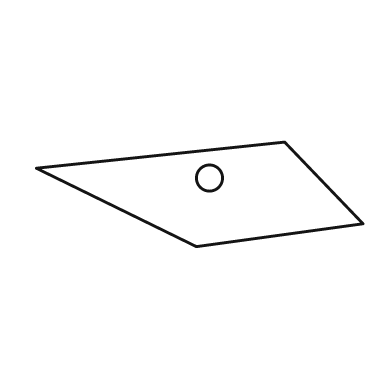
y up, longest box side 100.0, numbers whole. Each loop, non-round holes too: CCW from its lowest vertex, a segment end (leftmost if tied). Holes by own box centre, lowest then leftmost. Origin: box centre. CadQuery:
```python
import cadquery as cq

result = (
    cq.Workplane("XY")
    .moveTo(-1.0, -16.0)
    .lineTo(50.0, -9.0)
    .lineTo(26.0, 16.0)
    .lineTo(-50.0, 8.0)
    .close()
    .moveTo(3.0, 5.0)
    .circle(4.0)
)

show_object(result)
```